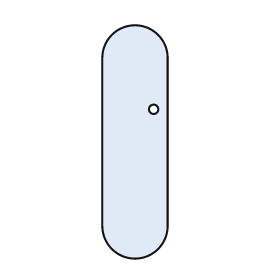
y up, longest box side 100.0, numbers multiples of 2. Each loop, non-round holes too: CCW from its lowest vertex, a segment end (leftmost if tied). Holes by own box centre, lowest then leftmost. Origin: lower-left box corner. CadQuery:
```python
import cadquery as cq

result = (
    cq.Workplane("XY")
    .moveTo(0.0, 14.0)
    .threePointArc((14.0, 0.0), (28.0, 14.0))
    .lineTo(28.0, 86.0)
    .threePointArc((14.0, 100.0), (0.0, 86.0))
    .close()
    .moveTo(22.0, 64.0)
    .circle(2.0)
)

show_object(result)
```